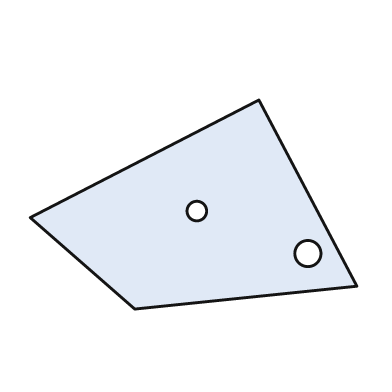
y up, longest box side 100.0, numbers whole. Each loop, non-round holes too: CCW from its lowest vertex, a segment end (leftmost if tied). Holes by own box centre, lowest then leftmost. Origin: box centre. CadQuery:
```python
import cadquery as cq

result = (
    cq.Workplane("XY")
    .moveTo(-18.0, -32.0)
    .lineTo(50.0, -25.0)
    .lineTo(20.0, 32.0)
    .lineTo(-50.0, -4.0)
    .close()
    .moveTo(35.0, -15.0)
    .circle(4.0)
    .moveTo(1.0, -2.0)
    .circle(3.0)
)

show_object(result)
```